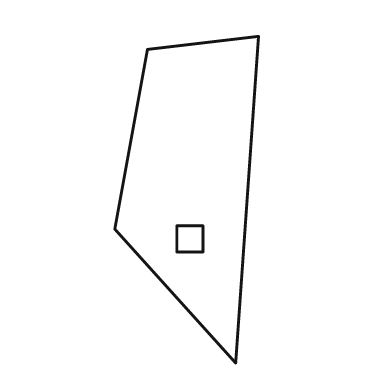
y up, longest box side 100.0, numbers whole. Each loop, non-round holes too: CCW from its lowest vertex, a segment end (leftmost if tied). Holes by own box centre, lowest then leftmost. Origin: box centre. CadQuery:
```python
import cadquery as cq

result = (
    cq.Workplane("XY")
    .moveTo(15.0, -50.0)
    .lineTo(22.0, 50.0)
    .lineTo(-12.0, 46.0)
    .lineTo(-22.0, -9.0)
    .close()
    .moveTo(-3.0, -16.0)
    .lineTo(5.0, -16.0)
    .lineTo(5.0, -8.0)
    .lineTo(-3.0, -8.0)
    .close()
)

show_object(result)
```